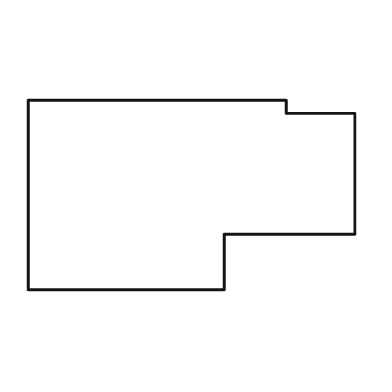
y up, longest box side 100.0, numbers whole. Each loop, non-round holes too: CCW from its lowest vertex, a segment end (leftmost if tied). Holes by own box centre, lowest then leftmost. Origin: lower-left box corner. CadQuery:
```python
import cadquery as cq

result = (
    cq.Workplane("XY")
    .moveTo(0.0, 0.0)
    .lineTo(60.0, 0.0)
    .lineTo(60.0, 17.0)
    .lineTo(100.0, 17.0)
    .lineTo(100.0, 54.0)
    .lineTo(79.0, 54.0)
    .lineTo(79.0, 58.0)
    .lineTo(0.0, 58.0)
    .close()
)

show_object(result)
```